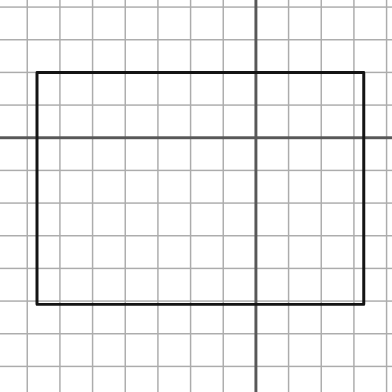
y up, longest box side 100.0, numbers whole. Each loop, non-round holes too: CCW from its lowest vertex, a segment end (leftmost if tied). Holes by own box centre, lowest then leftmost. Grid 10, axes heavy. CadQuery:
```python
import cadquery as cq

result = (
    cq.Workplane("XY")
    .moveTo(-67.0, -51.0)
    .lineTo(33.0, -51.0)
    .lineTo(33.0, 20.0)
    .lineTo(-67.0, 20.0)
    .close()
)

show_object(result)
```